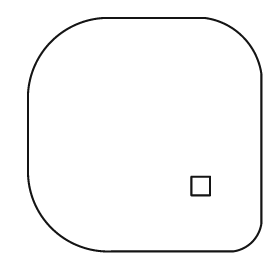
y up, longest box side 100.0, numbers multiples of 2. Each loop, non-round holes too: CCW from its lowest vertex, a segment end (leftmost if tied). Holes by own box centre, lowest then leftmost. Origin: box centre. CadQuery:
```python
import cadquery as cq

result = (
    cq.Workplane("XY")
    .moveTo(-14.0, -50.0)
    .lineTo(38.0, -50.0)
    .threePointArc((46.0, -46.0), (50.0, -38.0))
    .lineTo(50.0, 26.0)
    .threePointArc((42.0, 42.0), (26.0, 50.0))
    .lineTo(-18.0, 50.0)
    .threePointArc((-40.0, 40.0), (-50.0, 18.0))
    .lineTo(-50.0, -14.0)
    .threePointArc((-40.0, -40.0), (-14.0, -50.0))
    .close()
    .moveTo(20.0, -26.0)
    .lineTo(28.0, -26.0)
    .lineTo(28.0, -18.0)
    .lineTo(20.0, -18.0)
    .close()
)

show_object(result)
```